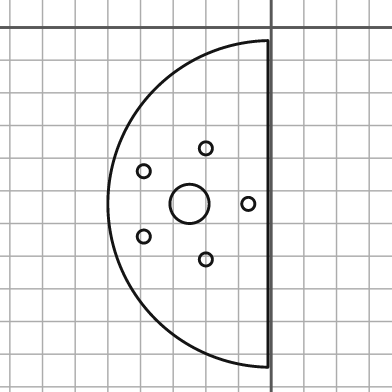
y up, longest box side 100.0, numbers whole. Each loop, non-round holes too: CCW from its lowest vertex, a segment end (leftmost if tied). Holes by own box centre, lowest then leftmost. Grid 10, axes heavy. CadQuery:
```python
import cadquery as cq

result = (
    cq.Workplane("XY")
    .moveTo(-1.0, -104.0)
    .lineTo(-1.0, -4.0)
    .threePointArc((-50.0, -54.0), (-1.0, -104.0))
    .close()
    .moveTo(-20.0, -71.0)
    .circle(2.0)
    .moveTo(-39.0, -64.0)
    .circle(2.0)
    .moveTo(-25.0, -54.0)
    .circle(6.0)
    .moveTo(-7.0, -54.0)
    .circle(2.0)
    .moveTo(-39.0, -44.0)
    .circle(2.0)
    .moveTo(-20.0, -37.0)
    .circle(2.0)
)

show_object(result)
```